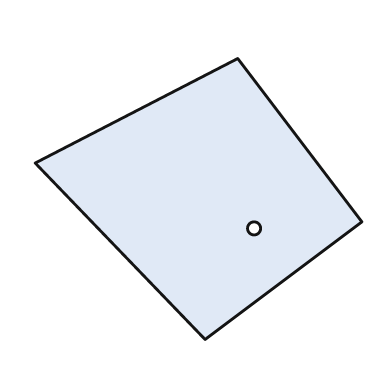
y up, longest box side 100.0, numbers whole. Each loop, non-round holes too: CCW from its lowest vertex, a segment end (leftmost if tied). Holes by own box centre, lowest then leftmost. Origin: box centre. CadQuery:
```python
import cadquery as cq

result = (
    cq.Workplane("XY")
    .moveTo(2.0, -43.0)
    .lineTo(50.0, -7.0)
    .lineTo(12.0, 43.0)
    .lineTo(-50.0, 11.0)
    .close()
    .moveTo(17.0, -9.0)
    .circle(2.0)
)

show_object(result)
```